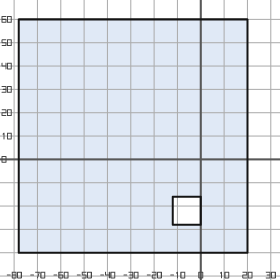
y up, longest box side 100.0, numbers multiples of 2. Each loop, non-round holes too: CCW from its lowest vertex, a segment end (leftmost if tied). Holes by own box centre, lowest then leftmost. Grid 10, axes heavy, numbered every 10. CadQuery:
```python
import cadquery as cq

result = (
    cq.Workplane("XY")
    .moveTo(-78.0, -40.0)
    .lineTo(20.0, -40.0)
    .lineTo(20.0, 60.0)
    .lineTo(-78.0, 60.0)
    .close()
    .moveTo(-12.0, -28.0)
    .lineTo(0.0, -28.0)
    .lineTo(0.0, -16.0)
    .lineTo(-12.0, -16.0)
    .close()
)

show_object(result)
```